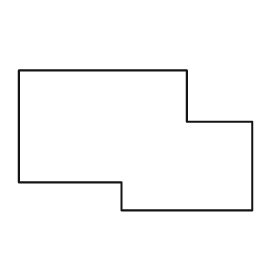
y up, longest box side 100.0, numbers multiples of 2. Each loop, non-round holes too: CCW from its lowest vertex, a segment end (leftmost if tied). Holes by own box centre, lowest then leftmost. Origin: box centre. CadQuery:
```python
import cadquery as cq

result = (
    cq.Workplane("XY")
    .moveTo(-6.0, -30.0)
    .lineTo(50.0, -30.0)
    .lineTo(50.0, 8.0)
    .lineTo(22.0, 8.0)
    .lineTo(22.0, 30.0)
    .lineTo(-50.0, 30.0)
    .lineTo(-50.0, -18.0)
    .lineTo(-6.0, -18.0)
    .close()
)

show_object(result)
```